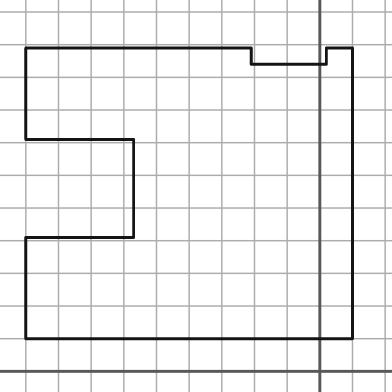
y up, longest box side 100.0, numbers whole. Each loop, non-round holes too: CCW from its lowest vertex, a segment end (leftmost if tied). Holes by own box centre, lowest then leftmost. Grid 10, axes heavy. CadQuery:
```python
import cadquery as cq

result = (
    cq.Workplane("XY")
    .moveTo(-90.0, 10.0)
    .lineTo(10.0, 10.0)
    .lineTo(10.0, 99.0)
    .lineTo(2.0, 99.0)
    .lineTo(2.0, 94.0)
    .lineTo(-21.0, 94.0)
    .lineTo(-21.0, 99.0)
    .lineTo(-90.0, 99.0)
    .lineTo(-90.0, 71.0)
    .lineTo(-57.0, 71.0)
    .lineTo(-57.0, 41.0)
    .lineTo(-90.0, 41.0)
    .close()
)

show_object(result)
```